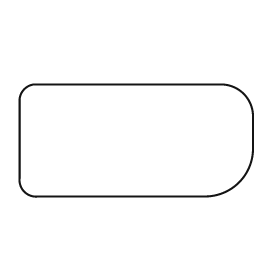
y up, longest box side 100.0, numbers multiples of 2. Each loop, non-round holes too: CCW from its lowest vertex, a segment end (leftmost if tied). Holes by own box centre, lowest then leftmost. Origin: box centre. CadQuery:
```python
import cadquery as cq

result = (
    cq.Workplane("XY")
    .moveTo(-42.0, -24.0)
    .lineTo(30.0, -24.0)
    .threePointArc((44.0, -18.0), (50.0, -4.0))
    .lineTo(50.0, 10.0)
    .threePointArc((46.0, 20.0), (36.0, 24.0))
    .lineTo(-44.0, 24.0)
    .threePointArc((-48.0, 22.0), (-50.0, 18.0))
    .lineTo(-50.0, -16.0)
    .threePointArc((-48.0, -22.0), (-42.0, -24.0))
    .close()
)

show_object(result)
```